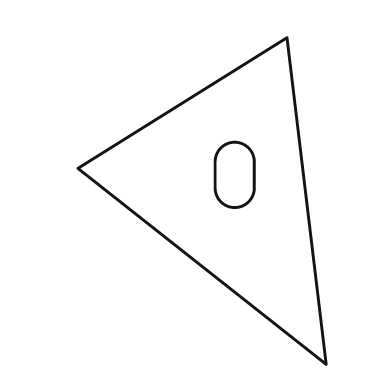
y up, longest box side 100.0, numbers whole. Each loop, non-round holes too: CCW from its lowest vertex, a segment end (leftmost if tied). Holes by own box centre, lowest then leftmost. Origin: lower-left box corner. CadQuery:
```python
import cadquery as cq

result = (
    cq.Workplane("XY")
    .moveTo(76.0, 0.0)
    .lineTo(64.0, 100.0)
    .lineTo(0.0, 60.0)
    .close()
    .moveTo(42.0, 54.0)
    .threePointArc((48.0, 48.0), (54.0, 54.0))
    .lineTo(54.0, 62.0)
    .threePointArc((48.0, 68.0), (42.0, 62.0))
    .close()
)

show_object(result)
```